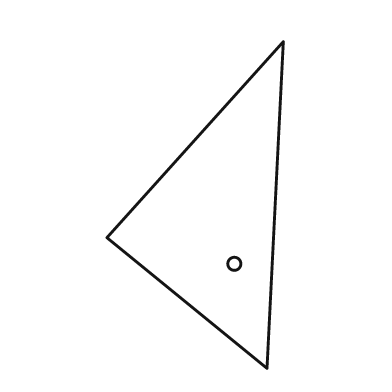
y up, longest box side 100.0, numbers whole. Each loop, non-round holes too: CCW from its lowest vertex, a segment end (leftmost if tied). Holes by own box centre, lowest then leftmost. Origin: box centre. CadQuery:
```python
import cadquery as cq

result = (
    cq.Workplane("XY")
    .moveTo(22.0, -50.0)
    .lineTo(27.0, 50.0)
    .lineTo(-27.0, -10.0)
    .close()
    .moveTo(12.0, -18.0)
    .circle(2.0)
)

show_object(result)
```